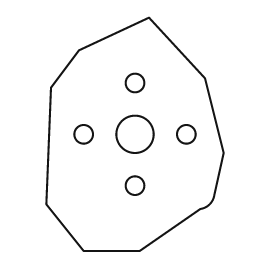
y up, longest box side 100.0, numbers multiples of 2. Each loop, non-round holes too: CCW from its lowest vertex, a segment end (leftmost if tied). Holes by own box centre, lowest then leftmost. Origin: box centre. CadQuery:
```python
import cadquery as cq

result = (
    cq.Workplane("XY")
    .moveTo(-22.0, -50.0)
    .lineTo(2.0, -50.0)
    .lineTo(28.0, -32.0)
    .threePointArc((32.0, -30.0), (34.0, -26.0))
    .lineTo(38.0, -8.0)
    .lineTo(30.0, 24.0)
    .lineTo(6.0, 50.0)
    .lineTo(-24.0, 36.0)
    .lineTo(-36.0, 20.0)
    .lineTo(-38.0, -30.0)
    .close()
    .moveTo(0.0, -22.0)
    .circle(4.0)
    .moveTo(-22.0, 0.0)
    .circle(4.0)
    .moveTo(0.0, 0.0)
    .circle(8.0)
    .moveTo(22.0, 0.0)
    .circle(4.0)
    .moveTo(0.0, 22.0)
    .circle(4.0)
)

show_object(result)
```